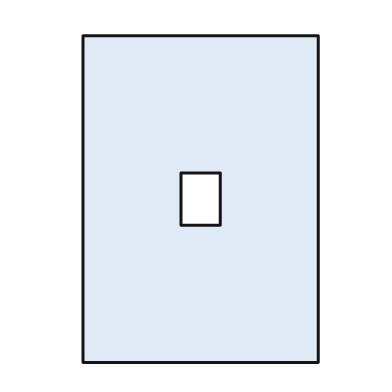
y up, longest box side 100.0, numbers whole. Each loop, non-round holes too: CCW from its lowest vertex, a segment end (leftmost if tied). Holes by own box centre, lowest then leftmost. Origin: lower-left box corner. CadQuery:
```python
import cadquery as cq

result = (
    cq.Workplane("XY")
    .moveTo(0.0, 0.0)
    .lineTo(72.0, 0.0)
    .lineTo(72.0, 100.0)
    .lineTo(0.0, 100.0)
    .close()
    .moveTo(30.0, 42.0)
    .lineTo(42.0, 42.0)
    .lineTo(42.0, 58.0)
    .lineTo(30.0, 58.0)
    .close()
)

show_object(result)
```